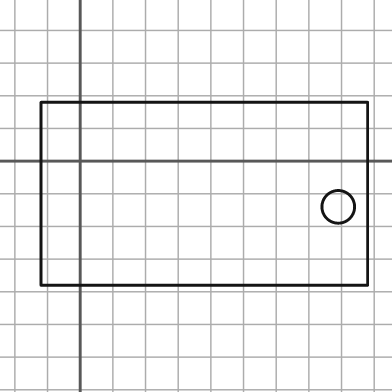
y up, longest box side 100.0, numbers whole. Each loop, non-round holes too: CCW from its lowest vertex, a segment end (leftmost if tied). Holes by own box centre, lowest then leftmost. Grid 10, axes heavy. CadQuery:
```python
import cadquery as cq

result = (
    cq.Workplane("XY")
    .moveTo(-12.0, -38.0)
    .lineTo(88.0, -38.0)
    .lineTo(88.0, 18.0)
    .lineTo(-12.0, 18.0)
    .close()
    .moveTo(79.0, -14.0)
    .circle(5.0)
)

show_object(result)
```